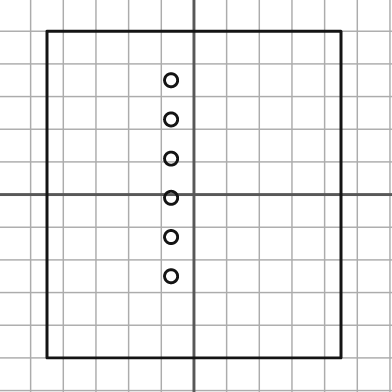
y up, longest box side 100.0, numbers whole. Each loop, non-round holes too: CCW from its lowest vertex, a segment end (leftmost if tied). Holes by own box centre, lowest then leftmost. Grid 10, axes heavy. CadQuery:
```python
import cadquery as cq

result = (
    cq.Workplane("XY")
    .moveTo(-45.0, -50.0)
    .lineTo(45.0, -50.0)
    .lineTo(45.0, 50.0)
    .lineTo(-45.0, 50.0)
    .close()
    .moveTo(-7.0, -25.0)
    .circle(2.0)
    .moveTo(-7.0, -13.0)
    .circle(2.0)
    .moveTo(-7.0, -1.0)
    .circle(2.0)
    .moveTo(-7.0, 11.0)
    .circle(2.0)
    .moveTo(-7.0, 23.0)
    .circle(2.0)
    .moveTo(-7.0, 35.0)
    .circle(2.0)
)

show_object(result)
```